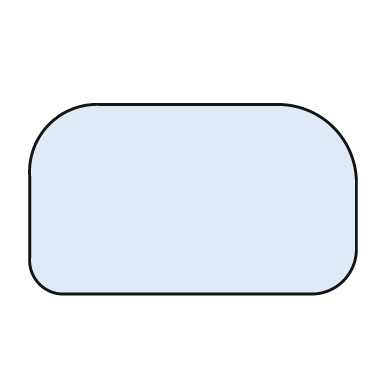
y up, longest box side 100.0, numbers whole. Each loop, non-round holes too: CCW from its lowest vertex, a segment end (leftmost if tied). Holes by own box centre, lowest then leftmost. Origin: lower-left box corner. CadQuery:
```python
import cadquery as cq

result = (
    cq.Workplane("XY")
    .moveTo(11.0, 0.0)
    .lineTo(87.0, 0.0)
    .threePointArc((96.0, 4.0), (100.0, 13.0))
    .lineTo(100.0, 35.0)
    .threePointArc((93.0, 51.0), (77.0, 58.0))
    .lineTo(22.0, 58.0)
    .threePointArc((6.0, 52.0), (0.0, 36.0))
    .lineTo(0.0, 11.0)
    .threePointArc((3.0, 3.0), (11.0, 0.0))
    .close()
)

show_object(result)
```